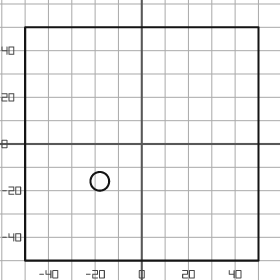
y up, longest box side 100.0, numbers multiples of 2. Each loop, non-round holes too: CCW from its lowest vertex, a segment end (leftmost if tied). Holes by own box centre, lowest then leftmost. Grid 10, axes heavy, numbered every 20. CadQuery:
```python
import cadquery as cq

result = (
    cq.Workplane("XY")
    .moveTo(-50.0, -50.0)
    .lineTo(50.0, -50.0)
    .lineTo(50.0, 50.0)
    .lineTo(-50.0, 50.0)
    .close()
    .moveTo(-18.0, -16.0)
    .circle(4.0)
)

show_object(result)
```